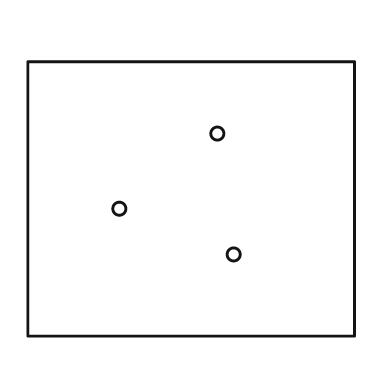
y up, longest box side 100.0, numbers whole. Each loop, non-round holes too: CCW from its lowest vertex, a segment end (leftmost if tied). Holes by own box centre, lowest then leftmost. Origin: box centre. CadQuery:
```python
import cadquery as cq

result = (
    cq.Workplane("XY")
    .moveTo(-50.0, -42.0)
    .lineTo(50.0, -42.0)
    .lineTo(50.0, 42.0)
    .lineTo(-50.0, 42.0)
    .close()
    .moveTo(13.0, -17.0)
    .circle(2.0)
    .moveTo(-22.0, -3.0)
    .circle(2.0)
    .moveTo(8.0, 20.0)
    .circle(2.0)
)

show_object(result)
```